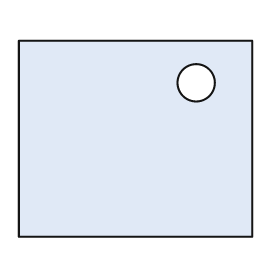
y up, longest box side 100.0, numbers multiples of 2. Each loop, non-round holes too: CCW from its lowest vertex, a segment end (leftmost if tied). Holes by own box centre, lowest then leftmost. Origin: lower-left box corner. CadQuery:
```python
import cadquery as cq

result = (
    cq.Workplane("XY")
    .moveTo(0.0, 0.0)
    .lineTo(100.0, 0.0)
    .lineTo(100.0, 84.0)
    .lineTo(0.0, 84.0)
    .close()
    .moveTo(76.0, 66.0)
    .circle(8.0)
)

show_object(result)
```